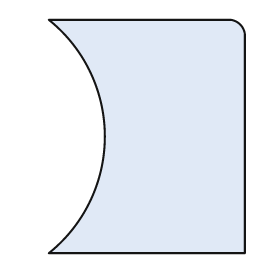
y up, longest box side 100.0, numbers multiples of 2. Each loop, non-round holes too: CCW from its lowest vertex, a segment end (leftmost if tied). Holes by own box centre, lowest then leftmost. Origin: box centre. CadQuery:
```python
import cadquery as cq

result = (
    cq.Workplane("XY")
    .moveTo(-42.0, -50.0)
    .lineTo(42.0, -50.0)
    .lineTo(42.0, 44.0)
    .threePointArc((40.0, 48.0), (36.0, 50.0))
    .lineTo(-42.0, 50.0)
    .threePointArc((-18.0, 0.0), (-42.0, -50.0))
    .close()
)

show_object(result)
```